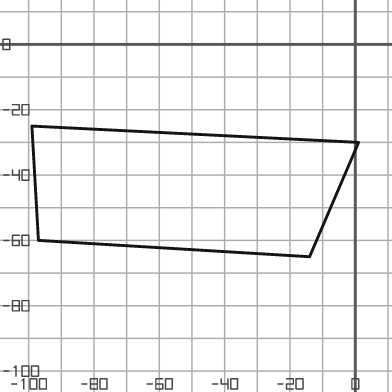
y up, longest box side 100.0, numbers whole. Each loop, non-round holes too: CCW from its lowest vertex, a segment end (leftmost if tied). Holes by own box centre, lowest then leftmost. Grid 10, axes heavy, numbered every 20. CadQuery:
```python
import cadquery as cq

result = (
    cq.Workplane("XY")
    .moveTo(-14.0, -65.0)
    .lineTo(1.0, -30.0)
    .lineTo(-99.0, -25.0)
    .lineTo(-97.0, -60.0)
    .close()
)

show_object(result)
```